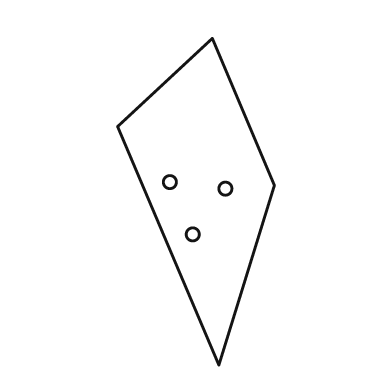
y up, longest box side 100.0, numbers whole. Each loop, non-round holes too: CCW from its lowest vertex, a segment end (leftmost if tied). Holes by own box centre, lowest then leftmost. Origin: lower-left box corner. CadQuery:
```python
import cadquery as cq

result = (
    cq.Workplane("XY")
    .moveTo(31.0, 0.0)
    .lineTo(48.0, 55.0)
    .lineTo(29.0, 100.0)
    .lineTo(0.0, 73.0)
    .close()
    .moveTo(23.0, 40.0)
    .circle(2.0)
    .moveTo(33.0, 54.0)
    .circle(2.0)
    .moveTo(16.0, 56.0)
    .circle(2.0)
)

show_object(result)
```